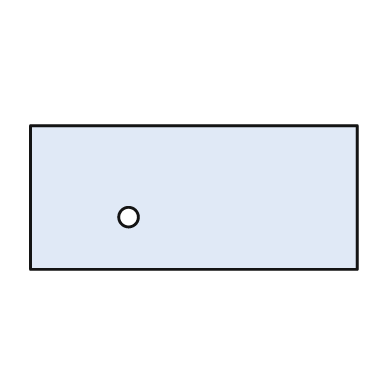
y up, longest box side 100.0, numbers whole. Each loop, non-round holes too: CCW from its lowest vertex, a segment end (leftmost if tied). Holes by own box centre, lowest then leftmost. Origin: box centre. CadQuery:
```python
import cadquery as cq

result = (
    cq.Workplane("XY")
    .moveTo(-50.0, -22.0)
    .lineTo(50.0, -22.0)
    .lineTo(50.0, 22.0)
    .lineTo(-50.0, 22.0)
    .close()
    .moveTo(-20.0, -6.0)
    .circle(3.0)
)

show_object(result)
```